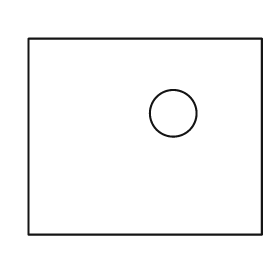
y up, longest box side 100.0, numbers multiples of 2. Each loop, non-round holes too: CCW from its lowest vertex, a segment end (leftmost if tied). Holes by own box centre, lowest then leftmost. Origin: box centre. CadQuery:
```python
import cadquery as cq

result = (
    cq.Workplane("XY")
    .moveTo(-50.0, -42.0)
    .lineTo(50.0, -42.0)
    .lineTo(50.0, 42.0)
    .lineTo(-50.0, 42.0)
    .close()
    .moveTo(12.0, 10.0)
    .circle(10.0)
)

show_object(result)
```